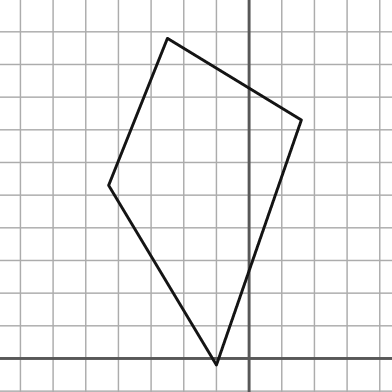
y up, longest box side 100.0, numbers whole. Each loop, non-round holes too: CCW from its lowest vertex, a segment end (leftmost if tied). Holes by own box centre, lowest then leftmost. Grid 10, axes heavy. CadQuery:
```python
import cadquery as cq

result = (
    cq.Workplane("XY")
    .moveTo(-10.0, -2.0)
    .lineTo(16.0, 73.0)
    .lineTo(-25.0, 98.0)
    .lineTo(-43.0, 53.0)
    .close()
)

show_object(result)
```